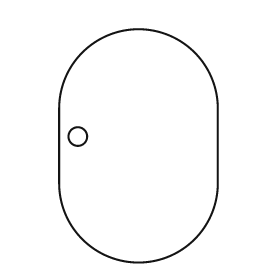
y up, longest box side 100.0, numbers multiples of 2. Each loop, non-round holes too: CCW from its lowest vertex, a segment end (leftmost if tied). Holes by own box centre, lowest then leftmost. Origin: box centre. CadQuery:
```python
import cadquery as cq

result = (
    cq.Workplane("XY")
    .moveTo(-34.0, -16.0)
    .threePointArc((0.0, -50.0), (34.0, -16.0))
    .lineTo(34.0, 16.0)
    .threePointArc((0.0, 50.0), (-34.0, 16.0))
    .close()
    .moveTo(-26.0, 4.0)
    .circle(4.0)
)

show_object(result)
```